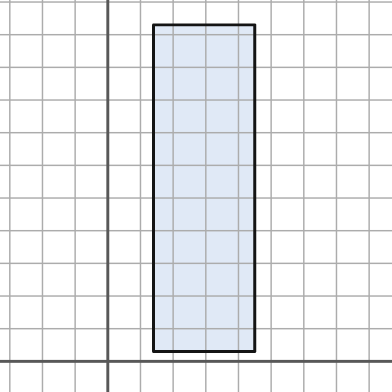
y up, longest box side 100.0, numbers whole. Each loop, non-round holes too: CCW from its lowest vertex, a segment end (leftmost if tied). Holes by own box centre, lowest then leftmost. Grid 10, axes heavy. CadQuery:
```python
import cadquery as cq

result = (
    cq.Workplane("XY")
    .moveTo(14.0, 3.0)
    .lineTo(45.0, 3.0)
    .lineTo(45.0, 103.0)
    .lineTo(14.0, 103.0)
    .close()
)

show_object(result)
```